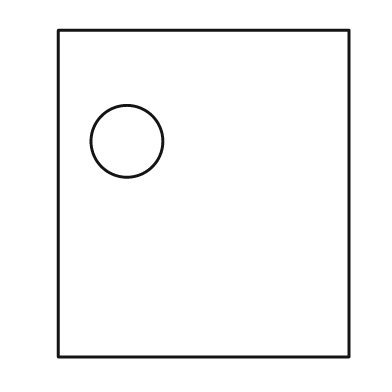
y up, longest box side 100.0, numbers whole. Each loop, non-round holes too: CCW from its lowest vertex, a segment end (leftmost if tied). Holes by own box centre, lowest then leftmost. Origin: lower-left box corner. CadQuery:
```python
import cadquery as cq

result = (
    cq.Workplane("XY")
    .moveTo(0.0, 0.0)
    .lineTo(89.0, 0.0)
    .lineTo(89.0, 100.0)
    .lineTo(0.0, 100.0)
    .close()
    .moveTo(21.0, 66.0)
    .circle(11.0)
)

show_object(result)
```